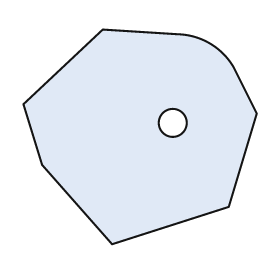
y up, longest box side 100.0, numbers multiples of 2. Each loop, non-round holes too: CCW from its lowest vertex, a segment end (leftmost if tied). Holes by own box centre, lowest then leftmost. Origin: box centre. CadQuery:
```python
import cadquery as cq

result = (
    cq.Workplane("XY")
    .moveTo(-12.0, -46.0)
    .lineTo(38.0, -30.0)
    .lineTo(50.0, 10.0)
    .lineTo(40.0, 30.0)
    .threePointArc((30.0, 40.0), (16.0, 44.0))
    .lineTo(-16.0, 46.0)
    .lineTo(-50.0, 14.0)
    .lineTo(-42.0, -12.0)
    .close()
    .moveTo(14.0, 6.0)
    .circle(6.0)
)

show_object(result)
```